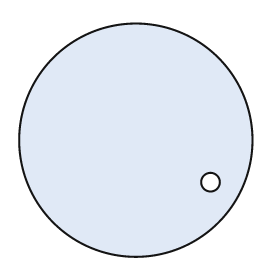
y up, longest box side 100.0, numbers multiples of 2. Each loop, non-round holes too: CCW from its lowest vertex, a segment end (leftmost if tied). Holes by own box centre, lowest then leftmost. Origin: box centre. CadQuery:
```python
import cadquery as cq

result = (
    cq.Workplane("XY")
    .moveTo(0.0, 0.0)
    .circle(50.0)
    .moveTo(32.0, -18.0)
    .circle(4.0)
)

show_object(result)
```